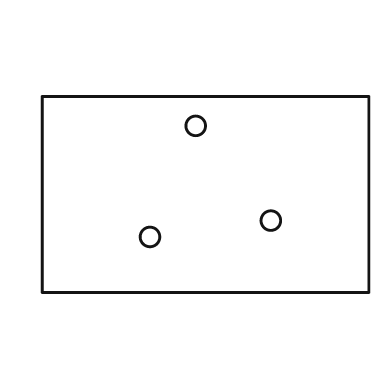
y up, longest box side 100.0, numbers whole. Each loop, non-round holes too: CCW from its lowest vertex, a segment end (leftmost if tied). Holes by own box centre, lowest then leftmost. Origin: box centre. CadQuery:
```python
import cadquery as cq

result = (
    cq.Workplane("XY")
    .moveTo(-50.0, -30.0)
    .lineTo(50.0, -30.0)
    .lineTo(50.0, 30.0)
    .lineTo(-50.0, 30.0)
    .close()
    .moveTo(-17.0, -13.0)
    .circle(3.0)
    .moveTo(20.0, -8.0)
    .circle(3.0)
    .moveTo(-3.0, 21.0)
    .circle(3.0)
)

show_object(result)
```